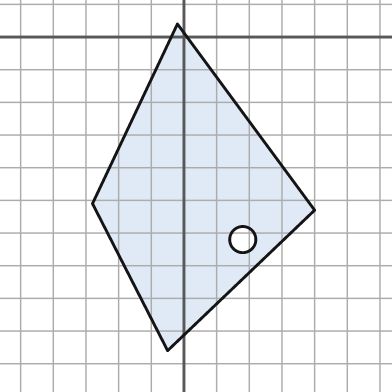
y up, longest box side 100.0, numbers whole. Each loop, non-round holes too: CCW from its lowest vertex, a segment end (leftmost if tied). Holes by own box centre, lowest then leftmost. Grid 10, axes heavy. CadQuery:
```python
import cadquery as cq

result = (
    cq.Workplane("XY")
    .moveTo(-5.0, -96.0)
    .lineTo(40.0, -53.0)
    .lineTo(-2.0, 4.0)
    .lineTo(-28.0, -51.0)
    .close()
    .moveTo(18.0, -62.0)
    .circle(4.0)
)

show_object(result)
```